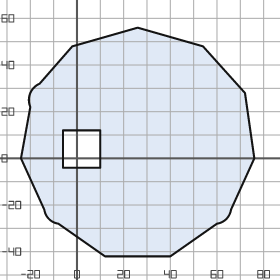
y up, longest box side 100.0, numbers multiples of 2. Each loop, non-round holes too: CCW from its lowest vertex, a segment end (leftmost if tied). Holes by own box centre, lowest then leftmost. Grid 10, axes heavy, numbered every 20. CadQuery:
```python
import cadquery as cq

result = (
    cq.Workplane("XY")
    .moveTo(12.0, -42.0)
    .lineTo(40.0, -42.0)
    .lineTo(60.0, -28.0)
    .threePointArc((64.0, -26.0), (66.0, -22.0))
    .lineTo(76.0, 0.0)
    .lineTo(72.0, 28.0)
    .lineTo(54.0, 48.0)
    .lineTo(26.0, 56.0)
    .lineTo(-2.0, 48.0)
    .lineTo(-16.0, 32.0)
    .threePointArc((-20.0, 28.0), (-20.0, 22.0))
    .lineTo(-24.0, 0.0)
    .lineTo(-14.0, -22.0)
    .threePointArc((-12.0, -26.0), (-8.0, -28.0))
    .close()
    .moveTo(-6.0, -4.0)
    .lineTo(10.0, -4.0)
    .lineTo(10.0, 12.0)
    .lineTo(-6.0, 12.0)
    .close()
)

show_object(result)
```